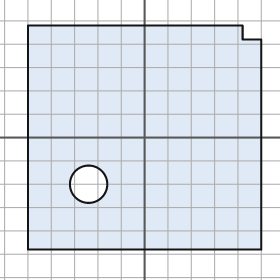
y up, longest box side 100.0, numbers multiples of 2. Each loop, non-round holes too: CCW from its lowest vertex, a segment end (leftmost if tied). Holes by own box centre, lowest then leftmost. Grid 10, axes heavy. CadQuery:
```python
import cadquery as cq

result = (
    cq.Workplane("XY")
    .moveTo(-50.0, -48.0)
    .lineTo(50.0, -48.0)
    .lineTo(50.0, 42.0)
    .lineTo(42.0, 42.0)
    .lineTo(42.0, 48.0)
    .lineTo(-50.0, 48.0)
    .close()
    .moveTo(-24.0, -20.0)
    .circle(8.0)
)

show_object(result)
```